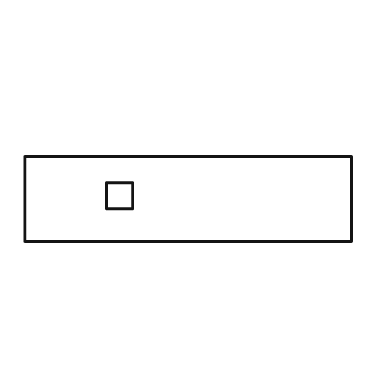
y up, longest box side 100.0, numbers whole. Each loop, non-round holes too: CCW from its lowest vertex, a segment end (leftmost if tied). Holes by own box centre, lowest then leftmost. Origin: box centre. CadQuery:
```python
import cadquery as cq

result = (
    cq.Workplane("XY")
    .moveTo(-50.0, -13.0)
    .lineTo(50.0, -13.0)
    .lineTo(50.0, 13.0)
    .lineTo(-50.0, 13.0)
    .close()
    .moveTo(-25.0, -3.0)
    .lineTo(-17.0, -3.0)
    .lineTo(-17.0, 5.0)
    .lineTo(-25.0, 5.0)
    .close()
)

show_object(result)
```